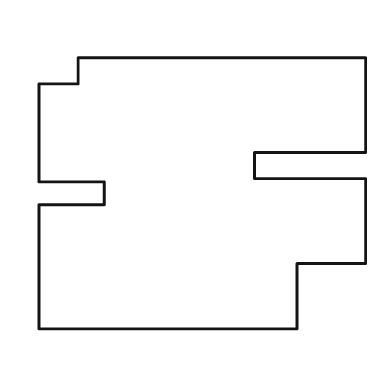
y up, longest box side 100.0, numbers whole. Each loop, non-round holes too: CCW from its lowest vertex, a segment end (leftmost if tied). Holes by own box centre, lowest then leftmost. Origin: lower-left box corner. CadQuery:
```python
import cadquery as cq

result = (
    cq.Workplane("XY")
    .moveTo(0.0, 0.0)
    .lineTo(79.0, 0.0)
    .lineTo(79.0, 20.0)
    .lineTo(100.0, 20.0)
    .lineTo(100.0, 46.0)
    .lineTo(66.0, 46.0)
    .lineTo(66.0, 54.0)
    .lineTo(100.0, 54.0)
    .lineTo(100.0, 83.0)
    .lineTo(12.0, 83.0)
    .lineTo(12.0, 75.0)
    .lineTo(0.0, 75.0)
    .lineTo(0.0, 45.0)
    .lineTo(20.0, 45.0)
    .lineTo(20.0, 38.0)
    .lineTo(0.0, 38.0)
    .close()
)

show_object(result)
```